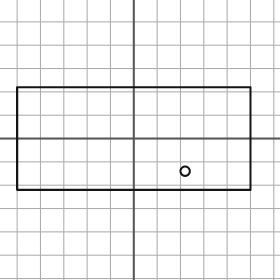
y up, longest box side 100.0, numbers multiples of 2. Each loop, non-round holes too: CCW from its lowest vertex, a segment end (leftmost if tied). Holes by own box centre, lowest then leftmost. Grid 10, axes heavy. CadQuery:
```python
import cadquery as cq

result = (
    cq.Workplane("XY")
    .moveTo(-50.0, -22.0)
    .lineTo(50.0, -22.0)
    .lineTo(50.0, 22.0)
    .lineTo(-50.0, 22.0)
    .close()
    .moveTo(22.0, -14.0)
    .circle(2.0)
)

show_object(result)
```